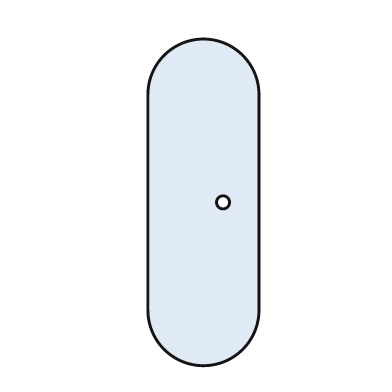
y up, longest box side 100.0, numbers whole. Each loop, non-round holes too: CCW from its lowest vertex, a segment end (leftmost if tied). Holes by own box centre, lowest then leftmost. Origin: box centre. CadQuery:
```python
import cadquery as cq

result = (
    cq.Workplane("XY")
    .moveTo(-17.0, -33.0)
    .threePointArc((0.0, -50.0), (17.0, -33.0))
    .lineTo(17.0, 33.0)
    .threePointArc((0.0, 50.0), (-17.0, 33.0))
    .close()
    .moveTo(6.0, 0.0)
    .circle(2.0)
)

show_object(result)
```